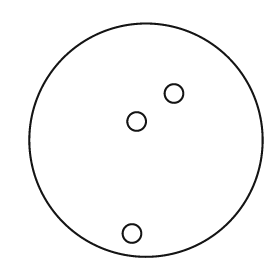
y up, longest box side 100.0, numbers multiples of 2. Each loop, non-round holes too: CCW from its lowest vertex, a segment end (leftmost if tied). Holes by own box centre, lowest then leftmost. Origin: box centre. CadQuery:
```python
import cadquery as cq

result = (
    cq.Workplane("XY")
    .moveTo(0.0, 0.0)
    .circle(50.0)
    .moveTo(-6.0, -40.0)
    .circle(4.0)
    .moveTo(-4.0, 8.0)
    .circle(4.0)
    .moveTo(12.0, 20.0)
    .circle(4.0)
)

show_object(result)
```